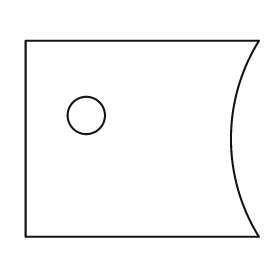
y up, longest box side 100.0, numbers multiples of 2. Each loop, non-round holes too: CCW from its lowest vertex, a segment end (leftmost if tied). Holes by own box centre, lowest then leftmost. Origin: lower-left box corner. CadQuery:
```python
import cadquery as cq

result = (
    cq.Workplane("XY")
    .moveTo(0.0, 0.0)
    .lineTo(100.0, 0.0)
    .threePointArc((88.0, 42.0), (100.0, 84.0))
    .lineTo(0.0, 84.0)
    .close()
    .moveTo(26.0, 52.0)
    .circle(8.0)
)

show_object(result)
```